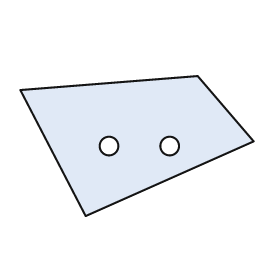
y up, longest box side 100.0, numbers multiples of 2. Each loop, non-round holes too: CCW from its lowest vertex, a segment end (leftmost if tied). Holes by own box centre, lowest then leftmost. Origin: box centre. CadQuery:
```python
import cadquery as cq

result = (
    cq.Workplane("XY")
    .moveTo(-22.0, -30.0)
    .lineTo(50.0, 2.0)
    .lineTo(26.0, 30.0)
    .lineTo(-50.0, 24.0)
    .close()
    .moveTo(-12.0, 0.0)
    .circle(4.0)
    .moveTo(14.0, 0.0)
    .circle(4.0)
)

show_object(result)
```